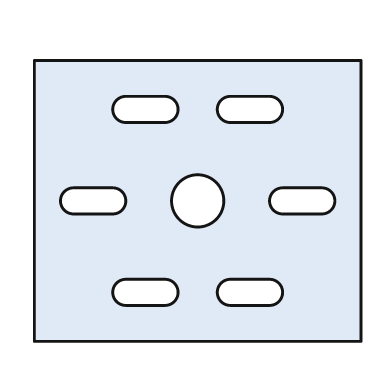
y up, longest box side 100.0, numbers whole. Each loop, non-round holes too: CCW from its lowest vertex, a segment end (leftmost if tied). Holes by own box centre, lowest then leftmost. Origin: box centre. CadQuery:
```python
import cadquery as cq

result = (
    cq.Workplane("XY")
    .moveTo(-50.0, -43.0)
    .lineTo(50.0, -43.0)
    .lineTo(50.0, 43.0)
    .lineTo(-50.0, 43.0)
    .close()
    .moveTo(-22.0, -32.0)
    .lineTo(-10.0, -32.0)
    .threePointArc((-6.0, -28.0), (-10.0, -24.0))
    .lineTo(-22.0, -24.0)
    .threePointArc((-26.0, -28.0), (-22.0, -32.0))
    .close()
    .moveTo(10.0, -32.0)
    .lineTo(22.0, -32.0)
    .threePointArc((26.0, -28.0), (22.0, -24.0))
    .lineTo(10.0, -24.0)
    .threePointArc((6.0, -28.0), (10.0, -32.0))
    .close()
    .moveTo(-38.0, -4.0)
    .lineTo(-26.0, -4.0)
    .threePointArc((-22.0, 0.0), (-26.0, 4.0))
    .lineTo(-38.0, 4.0)
    .threePointArc((-42.0, 0.0), (-38.0, -4.0))
    .close()
    .moveTo(0.0, 0.0)
    .circle(8.0)
    .moveTo(26.0, -4.0)
    .lineTo(38.0, -4.0)
    .threePointArc((42.0, 0.0), (38.0, 4.0))
    .lineTo(26.0, 4.0)
    .threePointArc((22.0, 0.0), (26.0, -4.0))
    .close()
    .moveTo(-22.0, 24.0)
    .lineTo(-10.0, 24.0)
    .threePointArc((-6.0, 28.0), (-10.0, 32.0))
    .lineTo(-22.0, 32.0)
    .threePointArc((-26.0, 28.0), (-22.0, 24.0))
    .close()
    .moveTo(10.0, 24.0)
    .lineTo(22.0, 24.0)
    .threePointArc((26.0, 28.0), (22.0, 32.0))
    .lineTo(10.0, 32.0)
    .threePointArc((6.0, 28.0), (10.0, 24.0))
    .close()
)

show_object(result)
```